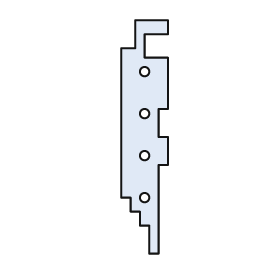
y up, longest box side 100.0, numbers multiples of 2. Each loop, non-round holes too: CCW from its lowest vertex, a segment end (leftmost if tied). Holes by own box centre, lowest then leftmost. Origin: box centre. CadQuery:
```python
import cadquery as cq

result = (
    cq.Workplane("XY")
    .moveTo(2.0, -50.0)
    .lineTo(6.0, -50.0)
    .lineTo(6.0, -12.0)
    .lineTo(10.0, -12.0)
    .lineTo(10.0, 0.0)
    .lineTo(6.0, 0.0)
    .lineTo(6.0, 12.0)
    .lineTo(10.0, 12.0)
    .lineTo(10.0, 34.0)
    .lineTo(0.0, 34.0)
    .lineTo(0.0, 44.0)
    .lineTo(10.0, 44.0)
    .lineTo(10.0, 50.0)
    .lineTo(-4.0, 50.0)
    .lineTo(-4.0, 38.0)
    .lineTo(-10.0, 38.0)
    .lineTo(-10.0, -26.0)
    .lineTo(-6.0, -26.0)
    .lineTo(-6.0, -32.0)
    .lineTo(-2.0, -32.0)
    .lineTo(-2.0, -38.0)
    .lineTo(2.0, -38.0)
    .close()
    .moveTo(0.0, -26.0)
    .circle(2.0)
    .moveTo(0.0, -8.0)
    .circle(2.0)
    .moveTo(0.0, 10.0)
    .circle(2.0)
    .moveTo(0.0, 28.0)
    .circle(2.0)
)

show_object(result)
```